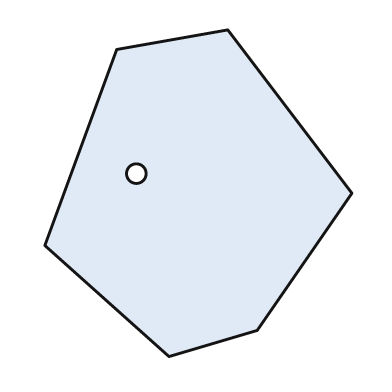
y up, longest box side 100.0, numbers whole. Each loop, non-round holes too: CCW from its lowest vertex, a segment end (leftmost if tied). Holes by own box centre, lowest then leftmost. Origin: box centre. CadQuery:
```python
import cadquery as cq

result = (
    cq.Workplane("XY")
    .moveTo(-9.0, -50.0)
    .lineTo(18.0, -42.0)
    .lineTo(47.0, 0.0)
    .lineTo(9.0, 50.0)
    .lineTo(-25.0, 44.0)
    .lineTo(-47.0, -16.0)
    .close()
    .moveTo(-19.0, 6.0)
    .circle(3.0)
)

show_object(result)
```